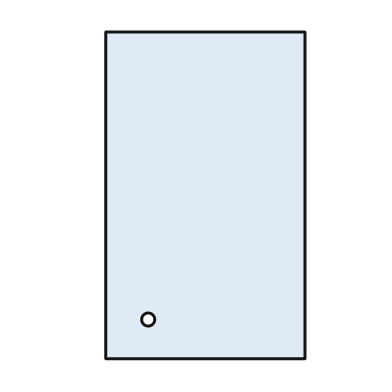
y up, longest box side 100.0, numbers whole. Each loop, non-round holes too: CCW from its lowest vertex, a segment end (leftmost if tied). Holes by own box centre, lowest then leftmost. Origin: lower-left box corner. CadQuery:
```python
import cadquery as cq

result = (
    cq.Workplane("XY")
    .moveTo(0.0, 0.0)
    .lineTo(61.0, 0.0)
    .lineTo(61.0, 100.0)
    .lineTo(0.0, 100.0)
    .close()
    .moveTo(13.0, 12.0)
    .circle(2.0)
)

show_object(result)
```